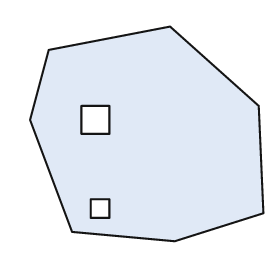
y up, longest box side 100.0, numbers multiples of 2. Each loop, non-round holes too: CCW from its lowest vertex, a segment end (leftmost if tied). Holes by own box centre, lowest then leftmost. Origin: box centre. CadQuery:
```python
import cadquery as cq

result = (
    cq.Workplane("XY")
    .moveTo(12.0, -46.0)
    .lineTo(50.0, -34.0)
    .lineTo(48.0, 12.0)
    .lineTo(10.0, 46.0)
    .lineTo(-42.0, 36.0)
    .lineTo(-50.0, 6.0)
    .lineTo(-32.0, -42.0)
    .close()
    .moveTo(-24.0, -36.0)
    .lineTo(-16.0, -36.0)
    .lineTo(-16.0, -28.0)
    .lineTo(-24.0, -28.0)
    .close()
    .moveTo(-28.0, 0.0)
    .lineTo(-16.0, 0.0)
    .lineTo(-16.0, 12.0)
    .lineTo(-28.0, 12.0)
    .close()
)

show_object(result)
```